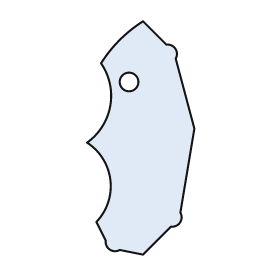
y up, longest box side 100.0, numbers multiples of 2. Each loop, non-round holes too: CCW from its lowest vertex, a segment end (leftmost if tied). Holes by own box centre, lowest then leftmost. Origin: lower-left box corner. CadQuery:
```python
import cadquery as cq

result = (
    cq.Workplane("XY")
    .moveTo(24.0, 0.0)
    .lineTo(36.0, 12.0)
    .threePointArc((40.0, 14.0), (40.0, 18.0))
    .lineTo(46.0, 54.0)
    .lineTo(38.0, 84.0)
    .threePointArc((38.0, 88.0), (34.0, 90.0))
    .lineTo(24.0, 100.0)
    .threePointArc((14.0, 92.0), (6.0, 82.0))
    .threePointArc((10.0, 64.0), (0.0, 48.0))
    .threePointArc((10.0, 32.0), (4.0, 14.0))
    .lineTo(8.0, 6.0)
    .threePointArc((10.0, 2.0), (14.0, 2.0))
    .close()
    .moveTo(18.0, 74.0)
    .circle(4.0)
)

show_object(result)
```